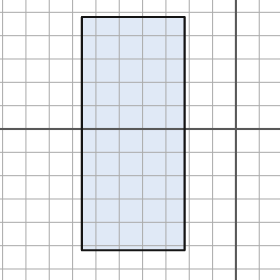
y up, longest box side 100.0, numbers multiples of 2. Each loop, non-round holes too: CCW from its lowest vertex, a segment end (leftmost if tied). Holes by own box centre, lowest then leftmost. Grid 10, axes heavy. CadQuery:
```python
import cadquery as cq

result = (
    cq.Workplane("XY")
    .moveTo(-66.0, -52.0)
    .lineTo(-22.0, -52.0)
    .lineTo(-22.0, 48.0)
    .lineTo(-66.0, 48.0)
    .close()
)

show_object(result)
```